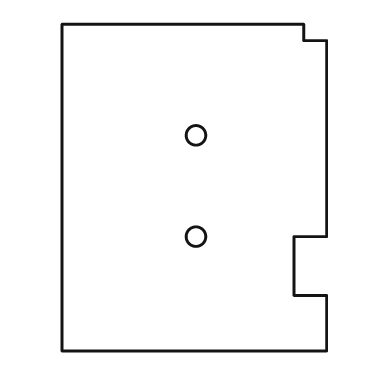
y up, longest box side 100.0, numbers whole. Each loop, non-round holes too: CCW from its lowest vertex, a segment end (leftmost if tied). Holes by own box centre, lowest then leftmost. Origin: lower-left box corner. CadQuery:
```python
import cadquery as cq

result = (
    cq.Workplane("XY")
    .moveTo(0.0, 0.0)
    .lineTo(81.0, 0.0)
    .lineTo(81.0, 17.0)
    .lineTo(71.0, 17.0)
    .lineTo(71.0, 35.0)
    .lineTo(81.0, 35.0)
    .lineTo(81.0, 95.0)
    .lineTo(74.0, 95.0)
    .lineTo(74.0, 100.0)
    .lineTo(0.0, 100.0)
    .close()
    .moveTo(41.0, 35.0)
    .circle(3.0)
    .moveTo(41.0, 66.0)
    .circle(3.0)
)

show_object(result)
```